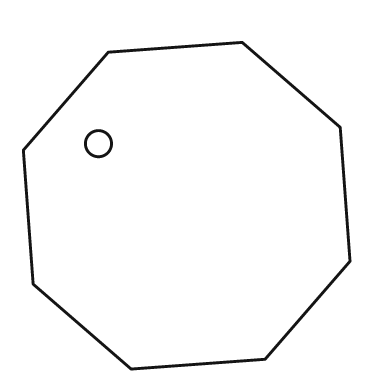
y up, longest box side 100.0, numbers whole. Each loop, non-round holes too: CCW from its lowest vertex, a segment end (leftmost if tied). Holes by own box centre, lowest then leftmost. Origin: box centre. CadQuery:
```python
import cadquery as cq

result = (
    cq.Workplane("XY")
    .moveTo(-17.0, -50.0)
    .lineTo(24.0, -47.0)
    .lineTo(50.0, -17.0)
    .lineTo(47.0, 24.0)
    .lineTo(17.0, 50.0)
    .lineTo(-24.0, 47.0)
    .lineTo(-50.0, 17.0)
    .lineTo(-47.0, -24.0)
    .close()
    .moveTo(-27.0, 19.0)
    .circle(4.0)
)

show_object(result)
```